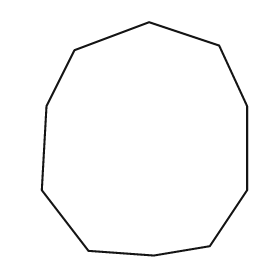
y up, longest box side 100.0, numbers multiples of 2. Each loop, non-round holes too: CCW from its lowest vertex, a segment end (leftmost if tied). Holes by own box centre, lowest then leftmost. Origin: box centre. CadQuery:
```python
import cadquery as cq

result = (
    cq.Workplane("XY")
    .moveTo(4.0, -50.0)
    .lineTo(28.0, -46.0)
    .lineTo(44.0, -22.0)
    .lineTo(44.0, 14.0)
    .lineTo(32.0, 40.0)
    .lineTo(2.0, 50.0)
    .lineTo(-30.0, 38.0)
    .lineTo(-42.0, 14.0)
    .lineTo(-44.0, -22.0)
    .lineTo(-24.0, -48.0)
    .close()
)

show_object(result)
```